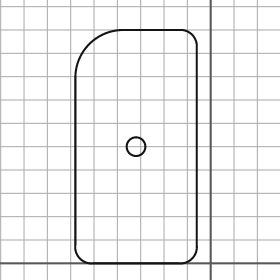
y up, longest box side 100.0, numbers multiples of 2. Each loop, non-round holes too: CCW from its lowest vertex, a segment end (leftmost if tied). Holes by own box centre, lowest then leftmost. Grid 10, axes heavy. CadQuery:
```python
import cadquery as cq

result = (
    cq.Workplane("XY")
    .moveTo(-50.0, 0.0)
    .lineTo(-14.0, 0.0)
    .threePointArc((-8.0, 2.0), (-6.0, 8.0))
    .lineTo(-6.0, 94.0)
    .threePointArc((-8.0, 98.0), (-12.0, 100.0))
    .lineTo(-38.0, 100.0)
    .threePointArc((-52.0, 94.0), (-58.0, 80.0))
    .lineTo(-58.0, 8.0)
    .threePointArc((-56.0, 2.0), (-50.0, 0.0))
    .close()
    .moveTo(-32.0, 50.0)
    .circle(4.0)
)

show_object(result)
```